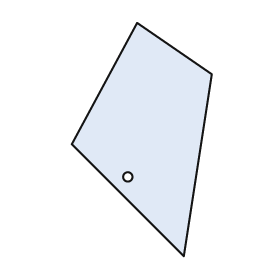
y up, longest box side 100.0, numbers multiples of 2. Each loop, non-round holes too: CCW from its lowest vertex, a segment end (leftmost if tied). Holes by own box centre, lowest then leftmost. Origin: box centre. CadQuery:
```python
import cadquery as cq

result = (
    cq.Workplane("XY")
    .moveTo(18.0, -50.0)
    .lineTo(30.0, 28.0)
    .lineTo(-2.0, 50.0)
    .lineTo(-30.0, -2.0)
    .close()
    .moveTo(-6.0, -16.0)
    .circle(2.0)
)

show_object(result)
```